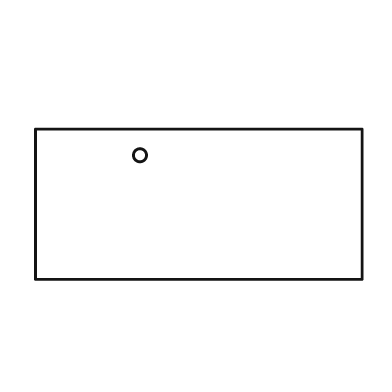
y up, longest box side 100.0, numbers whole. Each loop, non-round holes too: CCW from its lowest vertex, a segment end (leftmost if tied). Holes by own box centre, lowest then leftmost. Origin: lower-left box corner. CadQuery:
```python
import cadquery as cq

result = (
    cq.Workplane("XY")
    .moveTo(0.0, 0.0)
    .lineTo(100.0, 0.0)
    .lineTo(100.0, 46.0)
    .lineTo(0.0, 46.0)
    .close()
    .moveTo(32.0, 38.0)
    .circle(2.0)
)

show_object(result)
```